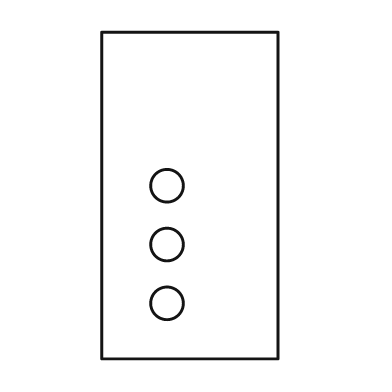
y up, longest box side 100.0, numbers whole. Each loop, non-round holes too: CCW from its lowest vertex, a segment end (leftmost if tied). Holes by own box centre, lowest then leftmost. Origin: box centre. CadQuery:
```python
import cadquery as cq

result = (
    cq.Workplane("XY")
    .moveTo(-27.0, -50.0)
    .lineTo(27.0, -50.0)
    .lineTo(27.0, 50.0)
    .lineTo(-27.0, 50.0)
    .close()
    .moveTo(-7.0, -33.0)
    .circle(5.0)
    .moveTo(-7.0, -15.0)
    .circle(5.0)
    .moveTo(-7.0, 3.0)
    .circle(5.0)
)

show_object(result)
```